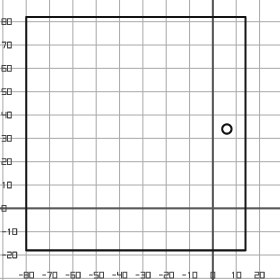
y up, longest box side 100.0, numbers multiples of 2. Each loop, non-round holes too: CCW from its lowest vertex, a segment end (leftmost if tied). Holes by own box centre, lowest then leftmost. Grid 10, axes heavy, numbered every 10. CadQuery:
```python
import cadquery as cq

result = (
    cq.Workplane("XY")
    .moveTo(-80.0, -18.0)
    .lineTo(14.0, -18.0)
    .lineTo(14.0, 82.0)
    .lineTo(-80.0, 82.0)
    .close()
    .moveTo(6.0, 34.0)
    .circle(2.0)
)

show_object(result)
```